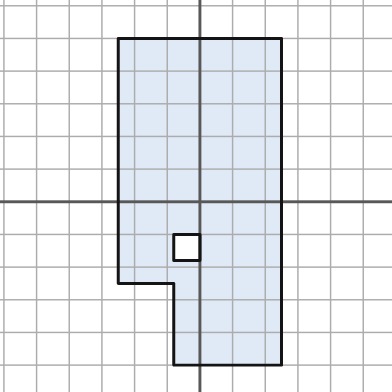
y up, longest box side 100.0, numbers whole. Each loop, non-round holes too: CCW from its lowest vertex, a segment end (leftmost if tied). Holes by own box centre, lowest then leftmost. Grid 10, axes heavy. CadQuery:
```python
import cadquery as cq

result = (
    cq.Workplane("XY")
    .moveTo(-8.0, -50.0)
    .lineTo(25.0, -50.0)
    .lineTo(25.0, 50.0)
    .lineTo(-25.0, 50.0)
    .lineTo(-25.0, -25.0)
    .lineTo(-8.0, -25.0)
    .close()
    .moveTo(-8.0, -18.0)
    .lineTo(0.0, -18.0)
    .lineTo(0.0, -10.0)
    .lineTo(-8.0, -10.0)
    .close()
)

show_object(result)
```